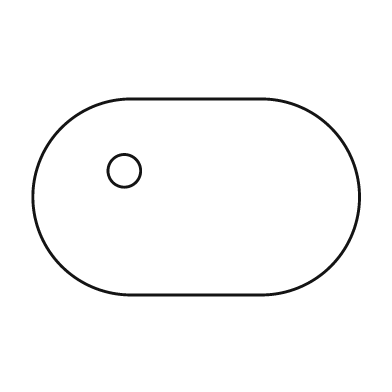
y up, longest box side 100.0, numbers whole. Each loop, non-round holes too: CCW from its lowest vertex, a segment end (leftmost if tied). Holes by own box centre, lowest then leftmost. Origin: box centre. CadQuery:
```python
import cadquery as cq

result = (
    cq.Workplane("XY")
    .moveTo(-20.0, -30.0)
    .lineTo(20.0, -30.0)
    .threePointArc((50.0, 0.0), (20.0, 30.0))
    .lineTo(-20.0, 30.0)
    .threePointArc((-50.0, 0.0), (-20.0, -30.0))
    .close()
    .moveTo(-22.0, 8.0)
    .circle(5.0)
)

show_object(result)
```